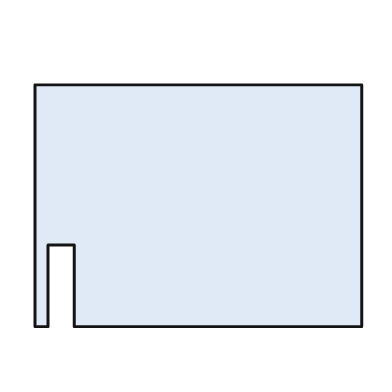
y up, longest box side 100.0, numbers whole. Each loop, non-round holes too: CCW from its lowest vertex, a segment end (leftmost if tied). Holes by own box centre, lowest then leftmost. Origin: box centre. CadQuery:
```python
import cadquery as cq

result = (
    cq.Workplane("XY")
    .moveTo(-50.0, -37.0)
    .lineTo(-46.0, -37.0)
    .lineTo(-46.0, -12.0)
    .lineTo(-38.0, -12.0)
    .lineTo(-38.0, -37.0)
    .lineTo(50.0, -37.0)
    .lineTo(50.0, 37.0)
    .lineTo(-50.0, 37.0)
    .close()
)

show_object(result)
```